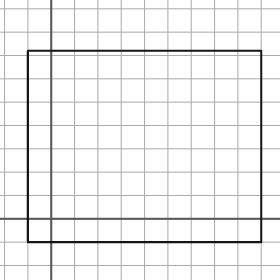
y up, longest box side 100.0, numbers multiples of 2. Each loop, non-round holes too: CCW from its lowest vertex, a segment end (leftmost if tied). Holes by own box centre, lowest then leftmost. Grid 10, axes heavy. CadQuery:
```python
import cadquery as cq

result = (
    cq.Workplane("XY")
    .moveTo(-10.0, -10.0)
    .lineTo(90.0, -10.0)
    .lineTo(90.0, 72.0)
    .lineTo(-10.0, 72.0)
    .close()
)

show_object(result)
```